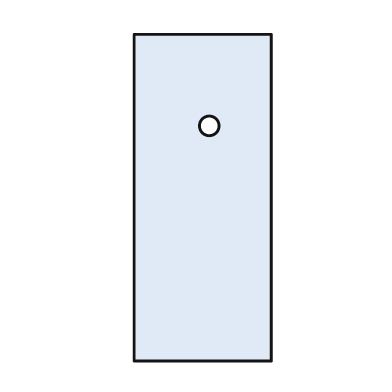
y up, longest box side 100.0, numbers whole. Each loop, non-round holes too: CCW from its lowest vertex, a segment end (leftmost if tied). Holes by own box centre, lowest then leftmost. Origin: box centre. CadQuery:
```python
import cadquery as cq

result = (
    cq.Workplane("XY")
    .moveTo(-21.0, -50.0)
    .lineTo(21.0, -50.0)
    .lineTo(21.0, 50.0)
    .lineTo(-21.0, 50.0)
    .close()
    .moveTo(2.0, 22.0)
    .circle(3.0)
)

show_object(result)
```